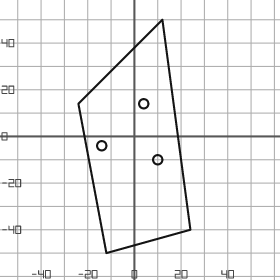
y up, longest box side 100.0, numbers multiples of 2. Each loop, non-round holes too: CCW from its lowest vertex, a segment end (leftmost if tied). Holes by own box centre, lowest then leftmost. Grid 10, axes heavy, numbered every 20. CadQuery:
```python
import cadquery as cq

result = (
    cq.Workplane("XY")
    .moveTo(-12.0, -50.0)
    .lineTo(24.0, -40.0)
    .lineTo(12.0, 50.0)
    .lineTo(-24.0, 14.0)
    .close()
    .moveTo(10.0, -10.0)
    .circle(2.0)
    .moveTo(-14.0, -4.0)
    .circle(2.0)
    .moveTo(4.0, 14.0)
    .circle(2.0)
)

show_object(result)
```